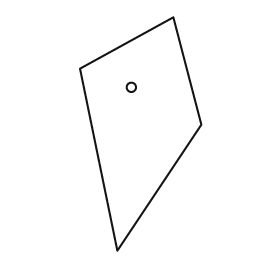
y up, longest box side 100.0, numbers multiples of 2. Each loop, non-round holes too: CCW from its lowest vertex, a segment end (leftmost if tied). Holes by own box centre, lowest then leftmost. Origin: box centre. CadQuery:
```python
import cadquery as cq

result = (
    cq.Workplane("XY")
    .moveTo(-10.0, -50.0)
    .lineTo(26.0, 4.0)
    .lineTo(14.0, 50.0)
    .lineTo(-26.0, 28.0)
    .close()
    .moveTo(-4.0, 20.0)
    .circle(2.0)
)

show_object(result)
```